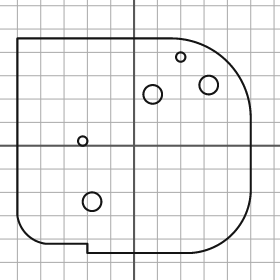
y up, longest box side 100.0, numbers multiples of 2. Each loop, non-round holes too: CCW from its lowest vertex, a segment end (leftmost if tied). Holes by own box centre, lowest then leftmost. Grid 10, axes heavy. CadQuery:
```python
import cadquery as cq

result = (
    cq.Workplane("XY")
    .moveTo(-20.0, -46.0)
    .lineTo(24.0, -46.0)
    .threePointArc((42.0, -38.0), (50.0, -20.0))
    .lineTo(50.0, 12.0)
    .threePointArc((40.0, 36.0), (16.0, 46.0))
    .lineTo(-50.0, 46.0)
    .lineTo(-50.0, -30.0)
    .threePointArc((-46.0, -38.0), (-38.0, -42.0))
    .lineTo(-20.0, -42.0)
    .close()
    .moveTo(-18.0, -24.0)
    .circle(4.0)
    .moveTo(-22.0, 2.0)
    .circle(2.0)
    .moveTo(8.0, 22.0)
    .circle(4.0)
    .moveTo(32.0, 26.0)
    .circle(4.0)
    .moveTo(20.0, 38.0)
    .circle(2.0)
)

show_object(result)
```